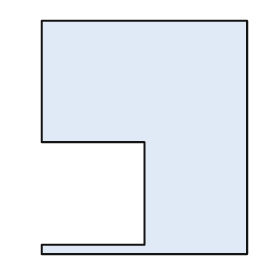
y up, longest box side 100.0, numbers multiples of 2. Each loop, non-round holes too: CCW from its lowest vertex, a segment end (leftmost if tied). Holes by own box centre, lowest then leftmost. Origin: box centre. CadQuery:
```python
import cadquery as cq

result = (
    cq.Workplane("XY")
    .moveTo(-44.0, -50.0)
    .lineTo(44.0, -50.0)
    .lineTo(44.0, 50.0)
    .lineTo(-44.0, 50.0)
    .lineTo(-44.0, -2.0)
    .lineTo(0.0, -2.0)
    .lineTo(0.0, -46.0)
    .lineTo(-44.0, -46.0)
    .close()
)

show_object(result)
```